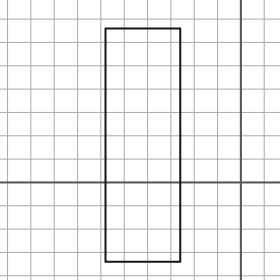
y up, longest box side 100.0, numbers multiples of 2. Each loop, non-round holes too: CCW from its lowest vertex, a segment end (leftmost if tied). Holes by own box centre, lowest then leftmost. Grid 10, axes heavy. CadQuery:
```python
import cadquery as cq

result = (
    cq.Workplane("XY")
    .moveTo(-58.0, -34.0)
    .lineTo(-26.0, -34.0)
    .lineTo(-26.0, 66.0)
    .lineTo(-58.0, 66.0)
    .close()
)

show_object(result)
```